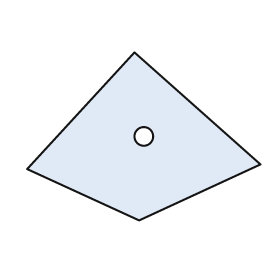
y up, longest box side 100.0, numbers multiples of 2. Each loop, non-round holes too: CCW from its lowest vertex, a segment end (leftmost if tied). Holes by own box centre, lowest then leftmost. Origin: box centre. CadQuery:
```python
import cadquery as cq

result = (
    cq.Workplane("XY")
    .moveTo(-2.0, -36.0)
    .lineTo(50.0, -12.0)
    .lineTo(-4.0, 36.0)
    .lineTo(-50.0, -14.0)
    .close()
    .moveTo(0.0, 0.0)
    .circle(4.0)
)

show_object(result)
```